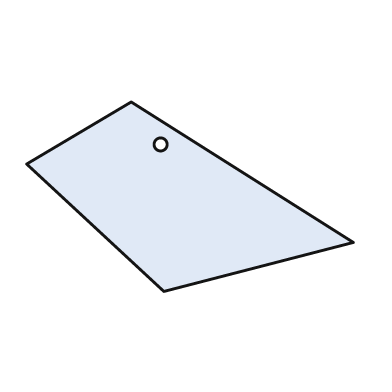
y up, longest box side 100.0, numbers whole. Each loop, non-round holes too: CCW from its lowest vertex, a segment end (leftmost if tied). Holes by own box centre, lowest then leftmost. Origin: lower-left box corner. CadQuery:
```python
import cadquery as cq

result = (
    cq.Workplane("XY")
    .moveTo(42.0, 0.0)
    .lineTo(100.0, 15.0)
    .lineTo(32.0, 58.0)
    .lineTo(0.0, 39.0)
    .close()
    .moveTo(41.0, 45.0)
    .circle(2.0)
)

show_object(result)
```